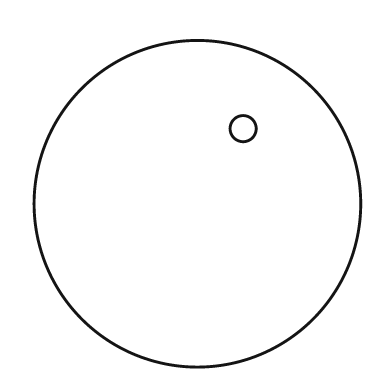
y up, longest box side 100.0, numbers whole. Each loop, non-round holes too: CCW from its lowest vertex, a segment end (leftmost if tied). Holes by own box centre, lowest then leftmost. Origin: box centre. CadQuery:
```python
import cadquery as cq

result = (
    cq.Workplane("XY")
    .moveTo(0.0, 0.0)
    .circle(50.0)
    .moveTo(14.0, 23.0)
    .circle(4.0)
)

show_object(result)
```